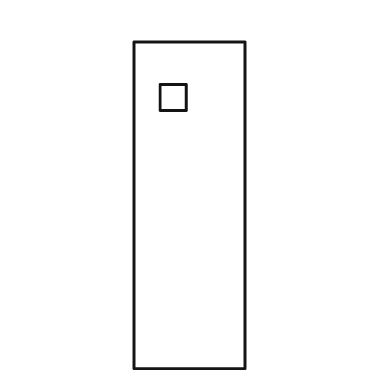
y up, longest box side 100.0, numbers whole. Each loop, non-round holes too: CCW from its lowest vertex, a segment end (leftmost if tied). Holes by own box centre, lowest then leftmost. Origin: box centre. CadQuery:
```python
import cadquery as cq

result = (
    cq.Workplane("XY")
    .moveTo(-17.0, -50.0)
    .lineTo(17.0, -50.0)
    .lineTo(17.0, 50.0)
    .lineTo(-17.0, 50.0)
    .close()
    .moveTo(-9.0, 29.0)
    .lineTo(-1.0, 29.0)
    .lineTo(-1.0, 37.0)
    .lineTo(-9.0, 37.0)
    .close()
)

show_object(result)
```